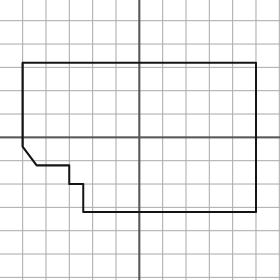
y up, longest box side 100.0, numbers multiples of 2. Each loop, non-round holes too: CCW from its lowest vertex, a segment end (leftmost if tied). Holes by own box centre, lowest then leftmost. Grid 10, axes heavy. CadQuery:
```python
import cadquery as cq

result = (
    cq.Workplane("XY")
    .moveTo(-24.0, -32.0)
    .lineTo(50.0, -32.0)
    .lineTo(50.0, 32.0)
    .lineTo(-50.0, 32.0)
    .lineTo(-50.0, -4.0)
    .lineTo(-44.0, -12.0)
    .lineTo(-30.0, -12.0)
    .lineTo(-30.0, -20.0)
    .lineTo(-24.0, -20.0)
    .close()
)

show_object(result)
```